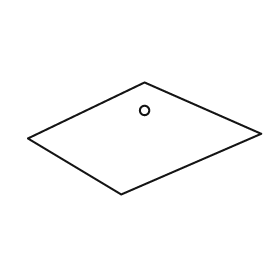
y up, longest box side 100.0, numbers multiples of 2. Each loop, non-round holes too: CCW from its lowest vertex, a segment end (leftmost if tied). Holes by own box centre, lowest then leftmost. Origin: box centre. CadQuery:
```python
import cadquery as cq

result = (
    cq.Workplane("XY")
    .moveTo(-10.0, -24.0)
    .lineTo(50.0, 2.0)
    .lineTo(0.0, 24.0)
    .lineTo(-50.0, 0.0)
    .close()
    .moveTo(0.0, 12.0)
    .circle(2.0)
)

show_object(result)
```